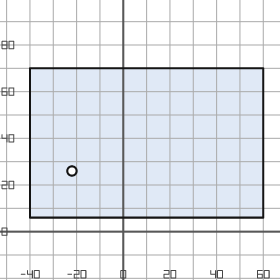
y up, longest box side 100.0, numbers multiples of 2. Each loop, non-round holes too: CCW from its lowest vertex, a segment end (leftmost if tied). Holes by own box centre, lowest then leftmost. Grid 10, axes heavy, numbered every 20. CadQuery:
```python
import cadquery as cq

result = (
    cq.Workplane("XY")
    .moveTo(-40.0, 6.0)
    .lineTo(60.0, 6.0)
    .lineTo(60.0, 70.0)
    .lineTo(-40.0, 70.0)
    .close()
    .moveTo(-22.0, 26.0)
    .circle(2.0)
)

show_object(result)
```